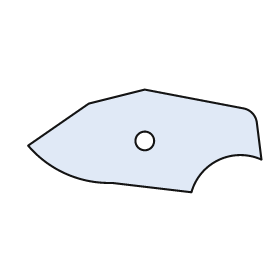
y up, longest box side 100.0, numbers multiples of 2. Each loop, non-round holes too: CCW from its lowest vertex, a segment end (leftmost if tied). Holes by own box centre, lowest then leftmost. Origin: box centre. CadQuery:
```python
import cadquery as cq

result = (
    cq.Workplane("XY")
    .moveTo(20.0, -22.0)
    .threePointArc((32.0, -8.0), (50.0, -8.0))
    .lineTo(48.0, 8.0)
    .threePointArc((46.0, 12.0), (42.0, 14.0))
    .lineTo(0.0, 22.0)
    .lineTo(-24.0, 16.0)
    .lineTo(-50.0, -2.0)
    .threePointArc((-34.0, -14.0), (-14.0, -18.0))
    .close()
    .moveTo(0.0, 0.0)
    .circle(4.0)
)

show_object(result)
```